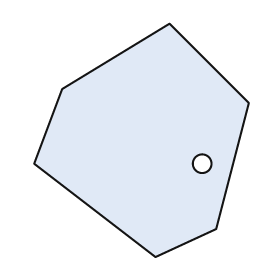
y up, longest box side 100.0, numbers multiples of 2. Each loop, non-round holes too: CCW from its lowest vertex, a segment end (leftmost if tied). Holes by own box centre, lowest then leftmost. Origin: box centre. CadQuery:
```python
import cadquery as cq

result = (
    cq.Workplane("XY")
    .moveTo(6.0, -50.0)
    .lineTo(32.0, -38.0)
    .lineTo(46.0, 16.0)
    .lineTo(12.0, 50.0)
    .lineTo(-34.0, 22.0)
    .lineTo(-46.0, -10.0)
    .close()
    .moveTo(26.0, -10.0)
    .circle(4.0)
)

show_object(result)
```